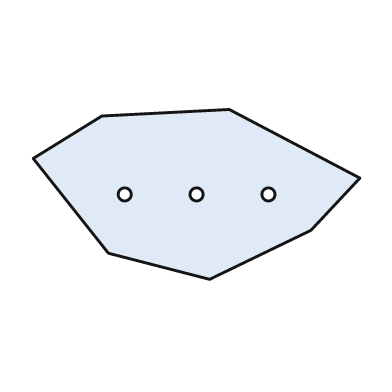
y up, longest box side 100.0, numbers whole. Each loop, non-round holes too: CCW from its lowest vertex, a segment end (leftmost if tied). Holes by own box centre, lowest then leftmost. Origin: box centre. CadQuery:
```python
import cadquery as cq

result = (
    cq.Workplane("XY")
    .moveTo(4.0, -26.0)
    .lineTo(35.0, -11.0)
    .lineTo(50.0, 5.0)
    .lineTo(10.0, 26.0)
    .lineTo(-29.0, 24.0)
    .lineTo(-50.0, 11.0)
    .lineTo(-27.0, -18.0)
    .close()
    .moveTo(-22.0, 0.0)
    .circle(2.0)
    .moveTo(0.0, 0.0)
    .circle(2.0)
    .moveTo(22.0, 0.0)
    .circle(2.0)
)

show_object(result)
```